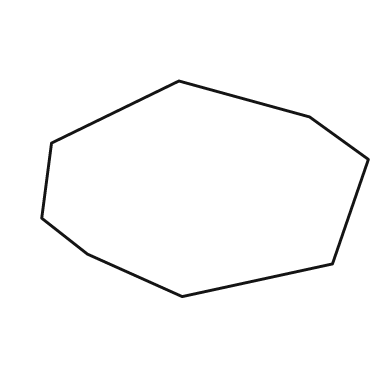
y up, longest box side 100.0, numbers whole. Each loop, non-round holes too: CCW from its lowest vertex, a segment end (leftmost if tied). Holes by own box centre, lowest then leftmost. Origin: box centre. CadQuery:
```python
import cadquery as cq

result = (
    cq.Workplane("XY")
    .moveTo(-7.0, -33.0)
    .lineTo(39.0, -23.0)
    .lineTo(50.0, 9.0)
    .lineTo(32.0, 22.0)
    .lineTo(-8.0, 33.0)
    .lineTo(-47.0, 14.0)
    .lineTo(-50.0, -9.0)
    .lineTo(-36.0, -20.0)
    .close()
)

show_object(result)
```